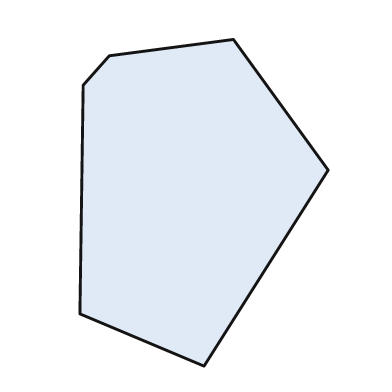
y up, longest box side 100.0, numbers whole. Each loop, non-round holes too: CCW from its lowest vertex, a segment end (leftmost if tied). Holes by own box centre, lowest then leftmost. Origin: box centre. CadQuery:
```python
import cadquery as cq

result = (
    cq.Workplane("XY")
    .moveTo(0.0, -50.0)
    .lineTo(38.0, 10.0)
    .lineTo(9.0, 50.0)
    .lineTo(-29.0, 45.0)
    .lineTo(-37.0, 36.0)
    .lineTo(-38.0, -34.0)
    .close()
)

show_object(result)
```